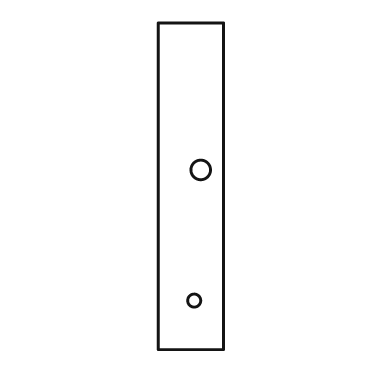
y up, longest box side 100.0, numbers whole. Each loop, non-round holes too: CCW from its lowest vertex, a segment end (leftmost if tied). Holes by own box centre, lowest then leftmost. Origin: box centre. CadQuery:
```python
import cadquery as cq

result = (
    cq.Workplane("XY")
    .moveTo(-10.0, -50.0)
    .lineTo(10.0, -50.0)
    .lineTo(10.0, 50.0)
    .lineTo(-10.0, 50.0)
    .close()
    .moveTo(1.0, -35.0)
    .circle(2.0)
    .moveTo(3.0, 5.0)
    .circle(3.0)
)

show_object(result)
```